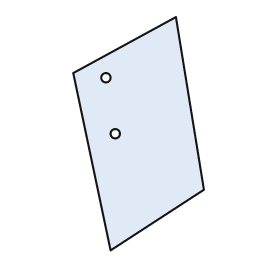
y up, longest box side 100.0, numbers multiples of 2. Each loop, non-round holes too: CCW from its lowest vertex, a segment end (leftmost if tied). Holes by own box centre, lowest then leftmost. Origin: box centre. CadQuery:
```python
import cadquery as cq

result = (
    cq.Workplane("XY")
    .moveTo(-12.0, -50.0)
    .lineTo(28.0, -24.0)
    .lineTo(16.0, 50.0)
    .lineTo(-28.0, 26.0)
    .close()
    .moveTo(-10.0, 0.0)
    .circle(2.0)
    .moveTo(-14.0, 24.0)
    .circle(2.0)
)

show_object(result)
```